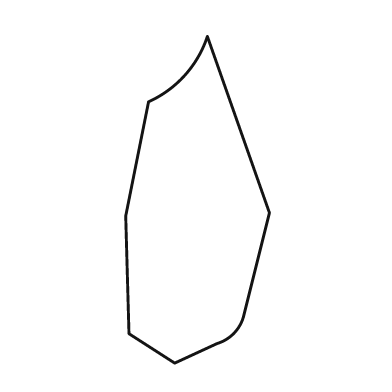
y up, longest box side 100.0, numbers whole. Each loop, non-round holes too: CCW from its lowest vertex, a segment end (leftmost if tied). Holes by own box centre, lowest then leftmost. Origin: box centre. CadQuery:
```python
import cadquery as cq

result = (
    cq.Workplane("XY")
    .moveTo(-7.0, -50.0)
    .lineTo(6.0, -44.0)
    .threePointArc((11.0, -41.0), (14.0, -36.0))
    .lineTo(22.0, -4.0)
    .lineTo(3.0, 50.0)
    .threePointArc((-4.0, 38.0), (-15.0, 30.0))
    .lineTo(-22.0, -5.0)
    .lineTo(-21.0, -41.0)
    .close()
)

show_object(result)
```